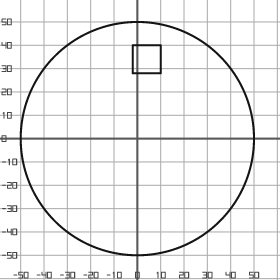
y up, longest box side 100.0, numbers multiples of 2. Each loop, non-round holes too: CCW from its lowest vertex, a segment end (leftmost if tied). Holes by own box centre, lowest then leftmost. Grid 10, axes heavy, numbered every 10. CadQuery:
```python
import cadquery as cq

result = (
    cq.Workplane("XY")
    .moveTo(0.0, 0.0)
    .circle(50.0)
    .moveTo(-2.0, 28.0)
    .lineTo(10.0, 28.0)
    .lineTo(10.0, 40.0)
    .lineTo(-2.0, 40.0)
    .close()
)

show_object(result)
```